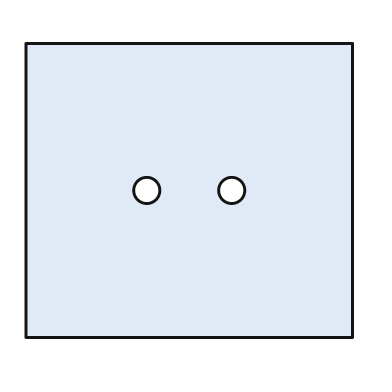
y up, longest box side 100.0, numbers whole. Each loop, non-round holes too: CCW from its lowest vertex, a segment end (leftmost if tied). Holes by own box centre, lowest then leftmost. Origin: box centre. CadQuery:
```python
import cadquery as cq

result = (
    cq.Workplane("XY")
    .moveTo(-50.0, -45.0)
    .lineTo(50.0, -45.0)
    .lineTo(50.0, 45.0)
    .lineTo(-50.0, 45.0)
    .close()
    .moveTo(-13.0, 0.0)
    .circle(4.0)
    .moveTo(13.0, 0.0)
    .circle(4.0)
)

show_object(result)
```